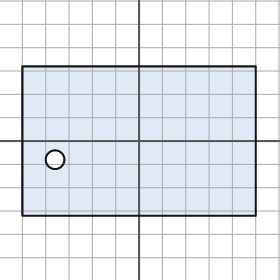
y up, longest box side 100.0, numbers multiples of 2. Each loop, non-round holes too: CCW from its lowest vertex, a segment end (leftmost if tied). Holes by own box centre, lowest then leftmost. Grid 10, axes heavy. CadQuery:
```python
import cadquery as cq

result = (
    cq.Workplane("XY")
    .moveTo(-50.0, -32.0)
    .lineTo(50.0, -32.0)
    .lineTo(50.0, 32.0)
    .lineTo(-50.0, 32.0)
    .close()
    .moveTo(-36.0, -8.0)
    .circle(4.0)
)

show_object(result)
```